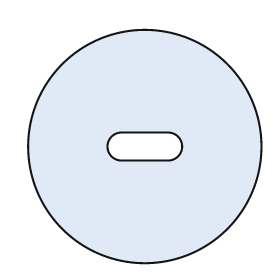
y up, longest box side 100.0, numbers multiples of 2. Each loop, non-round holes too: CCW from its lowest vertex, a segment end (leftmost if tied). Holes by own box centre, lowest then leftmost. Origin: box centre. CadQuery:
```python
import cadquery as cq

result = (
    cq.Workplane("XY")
    .moveTo(0.0, 0.0)
    .circle(50.0)
    .moveTo(-10.0, -6.0)
    .lineTo(10.0, -6.0)
    .threePointArc((16.0, 0.0), (10.0, 6.0))
    .lineTo(-10.0, 6.0)
    .threePointArc((-16.0, 0.0), (-10.0, -6.0))
    .close()
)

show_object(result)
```